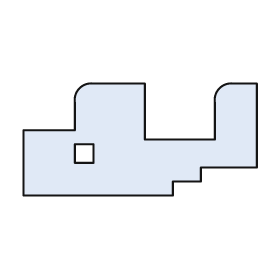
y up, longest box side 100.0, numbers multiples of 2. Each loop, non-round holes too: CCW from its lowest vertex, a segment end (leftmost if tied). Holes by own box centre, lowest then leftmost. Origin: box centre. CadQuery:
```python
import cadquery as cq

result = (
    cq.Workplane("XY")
    .moveTo(-50.0, -24.0)
    .lineTo(14.0, -24.0)
    .lineTo(14.0, -18.0)
    .lineTo(26.0, -18.0)
    .lineTo(26.0, -12.0)
    .lineTo(50.0, -12.0)
    .lineTo(50.0, 24.0)
    .lineTo(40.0, 24.0)
    .threePointArc((34.0, 22.0), (32.0, 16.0))
    .lineTo(32.0, 0.0)
    .lineTo(2.0, 0.0)
    .lineTo(2.0, 24.0)
    .lineTo(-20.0, 24.0)
    .threePointArc((-26.0, 22.0), (-28.0, 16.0))
    .lineTo(-28.0, 4.0)
    .lineTo(-50.0, 4.0)
    .close()
    .moveTo(-28.0, -10.0)
    .lineTo(-20.0, -10.0)
    .lineTo(-20.0, -2.0)
    .lineTo(-28.0, -2.0)
    .close()
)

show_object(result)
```